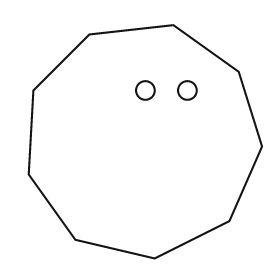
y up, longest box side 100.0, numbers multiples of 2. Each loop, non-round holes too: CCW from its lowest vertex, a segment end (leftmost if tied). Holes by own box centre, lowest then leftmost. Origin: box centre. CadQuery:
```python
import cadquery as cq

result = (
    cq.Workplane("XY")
    .moveTo(4.0, -50.0)
    .lineTo(36.0, -34.0)
    .lineTo(50.0, -2.0)
    .lineTo(40.0, 30.0)
    .lineTo(12.0, 50.0)
    .lineTo(-24.0, 46.0)
    .lineTo(-48.0, 22.0)
    .lineTo(-50.0, -14.0)
    .lineTo(-30.0, -42.0)
    .close()
    .moveTo(0.0, 22.0)
    .circle(4.0)
    .moveTo(18.0, 22.0)
    .circle(4.0)
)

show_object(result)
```